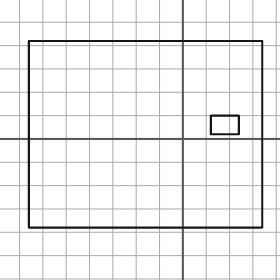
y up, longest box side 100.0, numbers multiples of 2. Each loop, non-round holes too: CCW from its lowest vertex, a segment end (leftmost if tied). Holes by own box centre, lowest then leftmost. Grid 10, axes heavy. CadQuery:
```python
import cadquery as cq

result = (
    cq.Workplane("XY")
    .moveTo(-66.0, -38.0)
    .lineTo(34.0, -38.0)
    .lineTo(34.0, 42.0)
    .lineTo(-66.0, 42.0)
    .close()
    .moveTo(12.0, 2.0)
    .lineTo(24.0, 2.0)
    .lineTo(24.0, 10.0)
    .lineTo(12.0, 10.0)
    .close()
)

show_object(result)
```